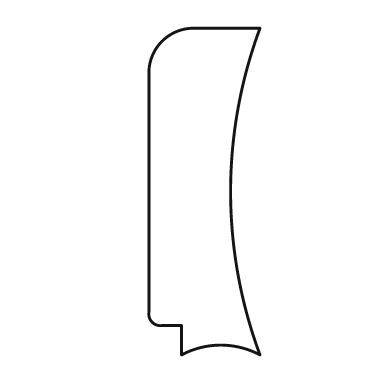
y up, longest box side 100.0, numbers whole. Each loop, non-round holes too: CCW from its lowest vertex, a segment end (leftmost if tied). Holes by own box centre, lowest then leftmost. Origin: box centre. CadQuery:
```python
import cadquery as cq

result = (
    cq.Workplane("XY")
    .moveTo(-7.0, -50.0)
    .threePointArc((5.0, -47.0), (17.0, -50.0))
    .threePointArc((8.0, 0.0), (17.0, 50.0))
    .lineTo(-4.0, 50.0)
    .threePointArc((-13.0, 46.0), (-17.0, 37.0))
    .lineTo(-17.0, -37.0)
    .threePointArc((-16.0, -40.0), (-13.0, -41.0))
    .lineTo(-7.0, -41.0)
    .close()
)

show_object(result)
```